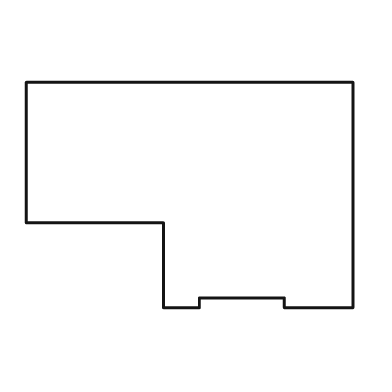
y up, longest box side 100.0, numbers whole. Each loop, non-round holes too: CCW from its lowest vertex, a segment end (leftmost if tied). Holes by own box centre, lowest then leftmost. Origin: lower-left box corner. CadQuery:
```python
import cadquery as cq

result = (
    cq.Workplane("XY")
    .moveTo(42.0, 0.0)
    .lineTo(53.0, 0.0)
    .lineTo(53.0, 3.0)
    .lineTo(79.0, 3.0)
    .lineTo(79.0, 0.0)
    .lineTo(100.0, 0.0)
    .lineTo(100.0, 69.0)
    .lineTo(0.0, 69.0)
    .lineTo(0.0, 26.0)
    .lineTo(42.0, 26.0)
    .close()
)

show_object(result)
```